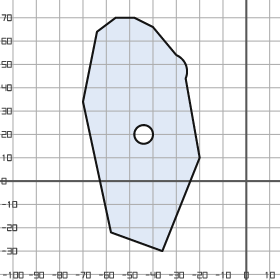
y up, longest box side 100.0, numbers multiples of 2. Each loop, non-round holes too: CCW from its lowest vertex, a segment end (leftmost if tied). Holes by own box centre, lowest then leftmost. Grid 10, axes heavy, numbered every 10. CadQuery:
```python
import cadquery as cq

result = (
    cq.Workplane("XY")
    .moveTo(-36.0, -30.0)
    .lineTo(-20.0, 10.0)
    .lineTo(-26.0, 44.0)
    .threePointArc((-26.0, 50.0), (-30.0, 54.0))
    .lineTo(-40.0, 66.0)
    .lineTo(-48.0, 70.0)
    .lineTo(-56.0, 70.0)
    .lineTo(-64.0, 64.0)
    .lineTo(-70.0, 34.0)
    .lineTo(-58.0, -22.0)
    .close()
    .moveTo(-44.0, 20.0)
    .circle(4.0)
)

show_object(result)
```